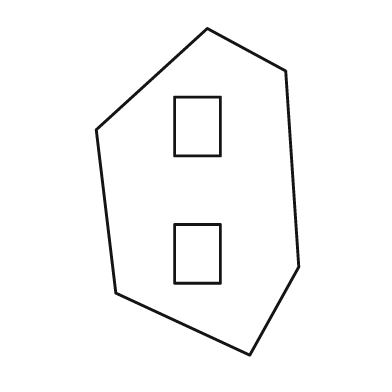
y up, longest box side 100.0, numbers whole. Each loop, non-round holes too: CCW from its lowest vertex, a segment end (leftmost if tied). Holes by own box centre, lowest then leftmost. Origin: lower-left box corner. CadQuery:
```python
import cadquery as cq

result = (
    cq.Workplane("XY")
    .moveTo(47.0, 0.0)
    .lineTo(62.0, 27.0)
    .lineTo(58.0, 87.0)
    .lineTo(34.0, 100.0)
    .lineTo(0.0, 69.0)
    .lineTo(6.0, 19.0)
    .close()
    .moveTo(24.0, 22.0)
    .lineTo(38.0, 22.0)
    .lineTo(38.0, 40.0)
    .lineTo(24.0, 40.0)
    .close()
    .moveTo(24.0, 61.0)
    .lineTo(38.0, 61.0)
    .lineTo(38.0, 79.0)
    .lineTo(24.0, 79.0)
    .close()
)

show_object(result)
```